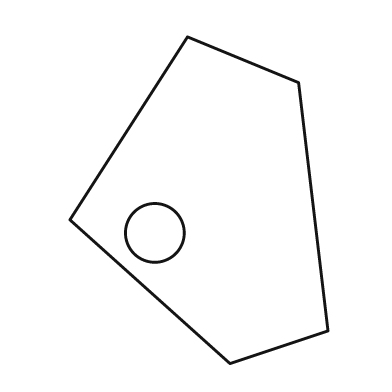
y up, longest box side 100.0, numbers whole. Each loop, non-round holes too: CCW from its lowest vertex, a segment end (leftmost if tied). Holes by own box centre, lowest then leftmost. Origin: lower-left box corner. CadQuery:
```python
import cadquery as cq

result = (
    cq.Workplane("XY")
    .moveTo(49.0, 0.0)
    .lineTo(79.0, 10.0)
    .lineTo(70.0, 86.0)
    .lineTo(36.0, 100.0)
    .lineTo(0.0, 44.0)
    .close()
    .moveTo(26.0, 40.0)
    .circle(9.0)
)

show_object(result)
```